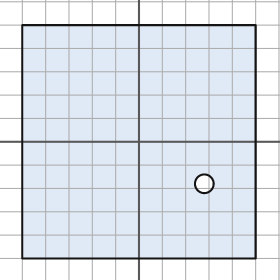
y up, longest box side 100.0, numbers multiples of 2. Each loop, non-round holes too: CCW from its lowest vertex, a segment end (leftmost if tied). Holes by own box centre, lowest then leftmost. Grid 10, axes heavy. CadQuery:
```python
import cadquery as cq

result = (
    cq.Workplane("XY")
    .moveTo(-50.0, -50.0)
    .lineTo(50.0, -50.0)
    .lineTo(50.0, 50.0)
    .lineTo(-50.0, 50.0)
    .close()
    .moveTo(28.0, -18.0)
    .circle(4.0)
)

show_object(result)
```